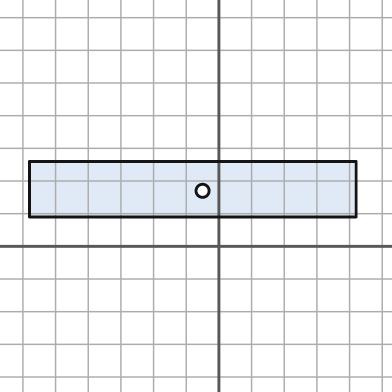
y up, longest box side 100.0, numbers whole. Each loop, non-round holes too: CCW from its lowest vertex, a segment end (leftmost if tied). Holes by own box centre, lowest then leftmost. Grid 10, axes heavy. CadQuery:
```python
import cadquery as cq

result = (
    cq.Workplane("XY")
    .moveTo(-58.0, 9.0)
    .lineTo(42.0, 9.0)
    .lineTo(42.0, 26.0)
    .lineTo(-58.0, 26.0)
    .close()
    .moveTo(-5.0, 17.0)
    .circle(2.0)
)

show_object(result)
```